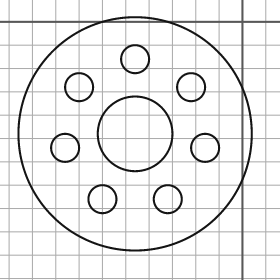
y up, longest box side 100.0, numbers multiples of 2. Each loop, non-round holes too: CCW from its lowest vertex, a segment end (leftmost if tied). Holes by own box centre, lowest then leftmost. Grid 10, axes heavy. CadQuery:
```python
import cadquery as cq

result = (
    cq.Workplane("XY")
    .moveTo(-46.0, -48.0)
    .circle(50.0)
    .moveTo(-60.0, -76.0)
    .circle(6.0)
    .moveTo(-32.0, -76.0)
    .circle(6.0)
    .moveTo(-76.0, -54.0)
    .circle(6.0)
    .moveTo(-16.0, -54.0)
    .circle(6.0)
    .moveTo(-46.0, -48.0)
    .circle(16.0)
    .moveTo(-70.0, -28.0)
    .circle(6.0)
    .moveTo(-22.0, -28.0)
    .circle(6.0)
    .moveTo(-46.0, -16.0)
    .circle(6.0)
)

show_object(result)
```